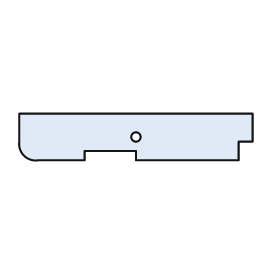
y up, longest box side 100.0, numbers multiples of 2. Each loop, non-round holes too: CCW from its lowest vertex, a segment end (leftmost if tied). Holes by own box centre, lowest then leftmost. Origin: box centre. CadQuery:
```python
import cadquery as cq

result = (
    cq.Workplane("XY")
    .moveTo(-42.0, -10.0)
    .lineTo(-22.0, -10.0)
    .lineTo(-22.0, -6.0)
    .lineTo(0.0, -6.0)
    .lineTo(0.0, -10.0)
    .lineTo(44.0, -10.0)
    .lineTo(44.0, -2.0)
    .lineTo(50.0, -2.0)
    .lineTo(50.0, 10.0)
    .lineTo(-50.0, 10.0)
    .lineTo(-50.0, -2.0)
    .threePointArc((-48.0, -8.0), (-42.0, -10.0))
    .close()
    .moveTo(0.0, 0.0)
    .circle(2.0)
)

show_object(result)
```